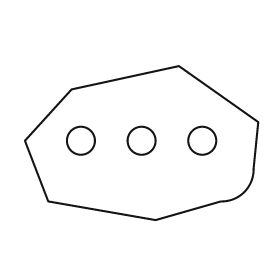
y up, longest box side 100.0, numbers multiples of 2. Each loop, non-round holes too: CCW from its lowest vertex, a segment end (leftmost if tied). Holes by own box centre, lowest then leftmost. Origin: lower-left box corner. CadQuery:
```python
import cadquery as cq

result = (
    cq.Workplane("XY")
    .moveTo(56.0, 0.0)
    .lineTo(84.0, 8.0)
    .threePointArc((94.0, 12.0), (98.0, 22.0))
    .lineTo(100.0, 42.0)
    .lineTo(66.0, 66.0)
    .lineTo(20.0, 56.0)
    .lineTo(0.0, 34.0)
    .lineTo(10.0, 8.0)
    .close()
    .moveTo(24.0, 34.0)
    .circle(6.0)
    .moveTo(50.0, 34.0)
    .circle(6.0)
    .moveTo(76.0, 34.0)
    .circle(6.0)
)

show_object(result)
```